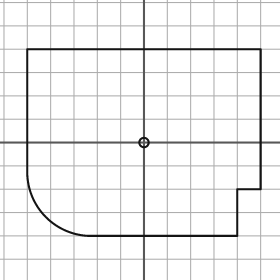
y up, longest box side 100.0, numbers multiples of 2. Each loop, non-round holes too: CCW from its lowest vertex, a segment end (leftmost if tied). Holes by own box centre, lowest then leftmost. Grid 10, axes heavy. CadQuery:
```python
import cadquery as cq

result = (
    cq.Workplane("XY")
    .moveTo(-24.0, -40.0)
    .lineTo(40.0, -40.0)
    .lineTo(40.0, -20.0)
    .lineTo(50.0, -20.0)
    .lineTo(50.0, 40.0)
    .lineTo(-50.0, 40.0)
    .lineTo(-50.0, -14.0)
    .threePointArc((-42.0, -32.0), (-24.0, -40.0))
    .close()
    .moveTo(0.0, 0.0)
    .circle(2.0)
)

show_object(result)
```